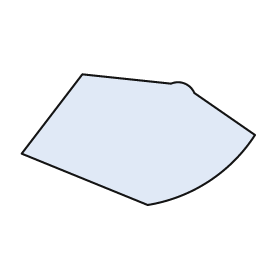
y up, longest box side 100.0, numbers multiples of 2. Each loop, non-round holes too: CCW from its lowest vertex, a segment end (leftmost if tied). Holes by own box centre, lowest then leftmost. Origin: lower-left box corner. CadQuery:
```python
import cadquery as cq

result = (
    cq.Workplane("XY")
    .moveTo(54.0, 0.0)
    .threePointArc((80.0, 10.0), (100.0, 30.0))
    .lineTo(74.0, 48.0)
    .threePointArc((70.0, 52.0), (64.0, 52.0))
    .lineTo(26.0, 56.0)
    .lineTo(0.0, 22.0)
    .close()
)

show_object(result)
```